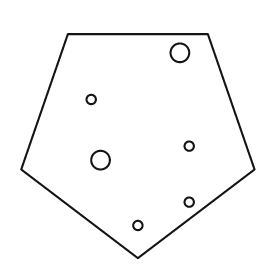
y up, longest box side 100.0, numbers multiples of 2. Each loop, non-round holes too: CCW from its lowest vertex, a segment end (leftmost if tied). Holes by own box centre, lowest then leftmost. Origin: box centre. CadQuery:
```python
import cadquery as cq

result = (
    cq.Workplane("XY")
    .moveTo(0.0, -48.0)
    .lineTo(50.0, -10.0)
    .lineTo(30.0, 48.0)
    .lineTo(-30.0, 48.0)
    .lineTo(-50.0, -10.0)
    .close()
    .moveTo(0.0, -34.0)
    .circle(2.0)
    .moveTo(22.0, -24.0)
    .circle(2.0)
    .moveTo(-16.0, -6.0)
    .circle(4.0)
    .moveTo(22.0, 0.0)
    .circle(2.0)
    .moveTo(-20.0, 20.0)
    .circle(2.0)
    .moveTo(18.0, 40.0)
    .circle(4.0)
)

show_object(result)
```